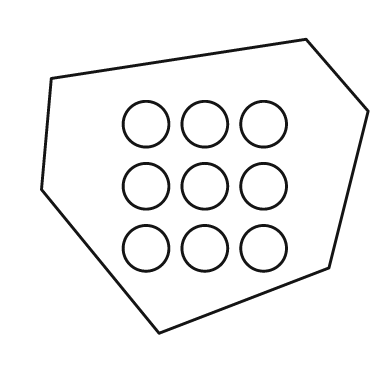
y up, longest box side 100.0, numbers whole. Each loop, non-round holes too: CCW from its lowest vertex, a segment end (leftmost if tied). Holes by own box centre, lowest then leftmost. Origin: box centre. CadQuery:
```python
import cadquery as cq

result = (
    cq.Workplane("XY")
    .moveTo(-14.0, -45.0)
    .lineTo(38.0, -25.0)
    .lineTo(50.0, 23.0)
    .lineTo(31.0, 45.0)
    .lineTo(-47.0, 33.0)
    .lineTo(-50.0, -1.0)
    .close()
    .moveTo(-18.0, -19.0)
    .circle(7.0)
    .moveTo(0.0, -19.0)
    .circle(7.0)
    .moveTo(18.0, -19.0)
    .circle(7.0)
    .moveTo(-18.0, 0.0)
    .circle(7.0)
    .moveTo(0.0, 0.0)
    .circle(7.0)
    .moveTo(18.0, 0.0)
    .circle(7.0)
    .moveTo(-18.0, 19.0)
    .circle(7.0)
    .moveTo(0.0, 19.0)
    .circle(7.0)
    .moveTo(18.0, 19.0)
    .circle(7.0)
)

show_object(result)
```